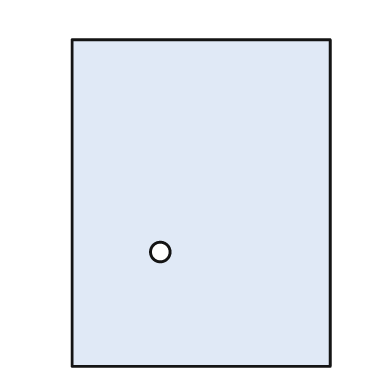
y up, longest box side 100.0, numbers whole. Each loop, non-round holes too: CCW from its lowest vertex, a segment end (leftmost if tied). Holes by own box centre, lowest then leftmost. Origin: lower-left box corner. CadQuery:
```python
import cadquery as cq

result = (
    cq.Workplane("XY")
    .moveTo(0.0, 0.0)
    .lineTo(79.0, 0.0)
    .lineTo(79.0, 100.0)
    .lineTo(0.0, 100.0)
    .close()
    .moveTo(27.0, 35.0)
    .circle(3.0)
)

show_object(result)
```